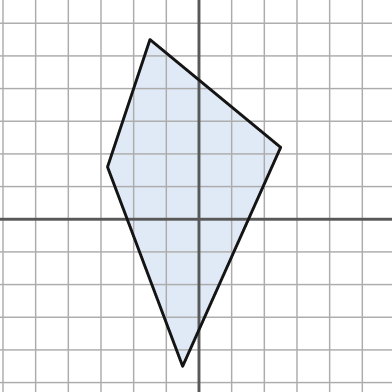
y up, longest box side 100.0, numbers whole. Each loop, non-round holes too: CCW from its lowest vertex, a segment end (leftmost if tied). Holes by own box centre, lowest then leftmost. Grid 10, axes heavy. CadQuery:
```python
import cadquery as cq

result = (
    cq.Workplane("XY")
    .moveTo(-5.0, -45.0)
    .lineTo(25.0, 22.0)
    .lineTo(-15.0, 55.0)
    .lineTo(-28.0, 16.0)
    .close()
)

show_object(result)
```